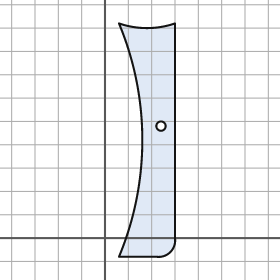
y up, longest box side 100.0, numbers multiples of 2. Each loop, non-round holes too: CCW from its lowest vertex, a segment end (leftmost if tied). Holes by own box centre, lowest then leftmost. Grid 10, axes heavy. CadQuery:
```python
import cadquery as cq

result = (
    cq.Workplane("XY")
    .moveTo(6.0, -8.0)
    .lineTo(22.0, -8.0)
    .threePointArc((28.0, -6.0), (30.0, 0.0))
    .lineTo(30.0, 92.0)
    .threePointArc((18.0, 90.0), (6.0, 92.0))
    .threePointArc((16.0, 42.0), (6.0, -8.0))
    .close()
    .moveTo(24.0, 48.0)
    .circle(2.0)
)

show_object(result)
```